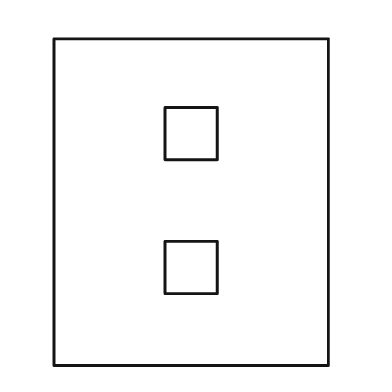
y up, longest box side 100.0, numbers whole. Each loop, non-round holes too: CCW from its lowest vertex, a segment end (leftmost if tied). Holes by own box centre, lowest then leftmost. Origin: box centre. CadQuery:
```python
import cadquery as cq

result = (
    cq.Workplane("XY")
    .moveTo(-42.0, -50.0)
    .lineTo(42.0, -50.0)
    .lineTo(42.0, 50.0)
    .lineTo(-42.0, 50.0)
    .close()
    .moveTo(-8.0, -28.0)
    .lineTo(8.0, -28.0)
    .lineTo(8.0, -12.0)
    .lineTo(-8.0, -12.0)
    .close()
    .moveTo(-8.0, 13.0)
    .lineTo(8.0, 13.0)
    .lineTo(8.0, 29.0)
    .lineTo(-8.0, 29.0)
    .close()
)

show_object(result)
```